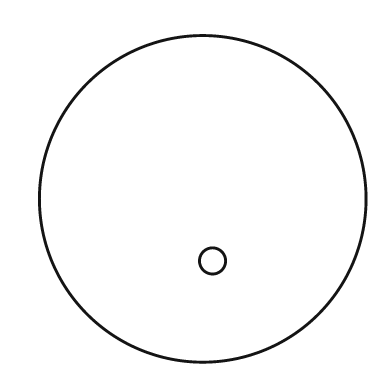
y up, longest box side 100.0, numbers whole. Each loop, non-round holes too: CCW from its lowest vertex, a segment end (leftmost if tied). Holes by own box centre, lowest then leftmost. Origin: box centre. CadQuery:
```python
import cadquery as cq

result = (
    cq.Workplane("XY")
    .moveTo(0.0, 0.0)
    .circle(50.0)
    .moveTo(3.0, -19.0)
    .circle(4.0)
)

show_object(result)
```